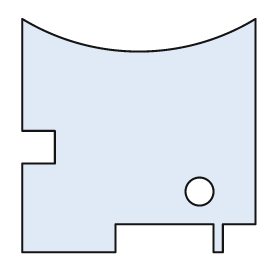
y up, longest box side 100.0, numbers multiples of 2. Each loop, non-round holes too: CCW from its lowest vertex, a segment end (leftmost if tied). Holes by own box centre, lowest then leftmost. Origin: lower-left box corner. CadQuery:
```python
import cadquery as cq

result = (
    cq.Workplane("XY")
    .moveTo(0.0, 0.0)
    .lineTo(40.0, 0.0)
    .lineTo(40.0, 12.0)
    .lineTo(82.0, 12.0)
    .lineTo(82.0, 0.0)
    .lineTo(86.0, 0.0)
    .lineTo(86.0, 12.0)
    .lineTo(100.0, 12.0)
    .lineTo(100.0, 100.0)
    .threePointArc((50.0, 86.0), (0.0, 100.0))
    .lineTo(0.0, 52.0)
    .lineTo(14.0, 52.0)
    .lineTo(14.0, 38.0)
    .lineTo(0.0, 38.0)
    .close()
    .moveTo(76.0, 26.0)
    .circle(6.0)
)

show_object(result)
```